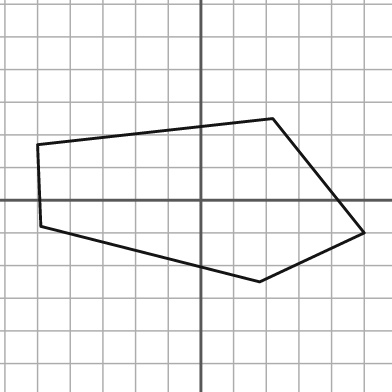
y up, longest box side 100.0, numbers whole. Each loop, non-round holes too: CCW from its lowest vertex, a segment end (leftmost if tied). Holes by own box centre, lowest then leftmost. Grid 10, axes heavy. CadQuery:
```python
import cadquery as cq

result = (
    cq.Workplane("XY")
    .moveTo(18.0, -25.0)
    .lineTo(50.0, -10.0)
    .lineTo(22.0, 25.0)
    .lineTo(-50.0, 17.0)
    .lineTo(-49.0, -8.0)
    .close()
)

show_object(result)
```